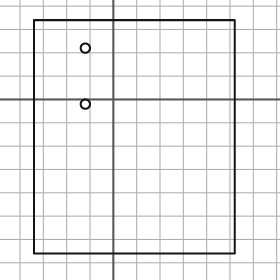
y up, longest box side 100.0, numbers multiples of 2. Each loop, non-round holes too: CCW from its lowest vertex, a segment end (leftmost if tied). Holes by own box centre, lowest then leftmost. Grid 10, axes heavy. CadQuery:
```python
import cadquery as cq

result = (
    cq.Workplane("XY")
    .moveTo(-34.0, -66.0)
    .lineTo(52.0, -66.0)
    .lineTo(52.0, 34.0)
    .lineTo(-34.0, 34.0)
    .close()
    .moveTo(-12.0, -2.0)
    .circle(2.0)
    .moveTo(-12.0, 22.0)
    .circle(2.0)
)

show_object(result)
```